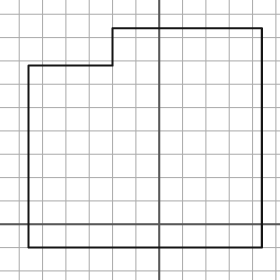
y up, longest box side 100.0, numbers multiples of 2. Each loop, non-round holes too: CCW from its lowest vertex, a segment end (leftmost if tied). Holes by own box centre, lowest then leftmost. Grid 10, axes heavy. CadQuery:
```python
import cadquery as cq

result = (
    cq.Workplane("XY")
    .moveTo(-56.0, -10.0)
    .lineTo(44.0, -10.0)
    .lineTo(44.0, 84.0)
    .lineTo(-20.0, 84.0)
    .lineTo(-20.0, 68.0)
    .lineTo(-56.0, 68.0)
    .close()
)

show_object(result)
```